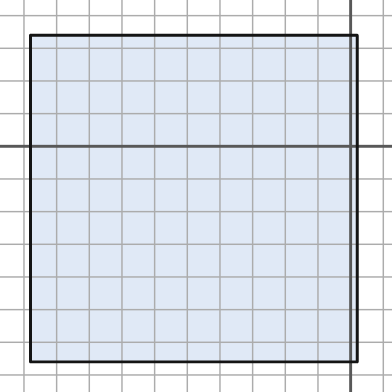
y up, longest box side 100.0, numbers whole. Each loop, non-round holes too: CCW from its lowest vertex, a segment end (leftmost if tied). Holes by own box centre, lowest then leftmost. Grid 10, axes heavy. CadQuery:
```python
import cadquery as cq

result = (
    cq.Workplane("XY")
    .moveTo(-98.0, -66.0)
    .lineTo(2.0, -66.0)
    .lineTo(2.0, 34.0)
    .lineTo(-98.0, 34.0)
    .close()
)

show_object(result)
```